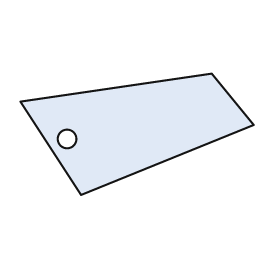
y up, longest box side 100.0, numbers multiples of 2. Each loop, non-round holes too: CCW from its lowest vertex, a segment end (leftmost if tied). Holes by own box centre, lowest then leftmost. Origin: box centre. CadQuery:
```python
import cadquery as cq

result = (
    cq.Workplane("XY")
    .moveTo(-24.0, -26.0)
    .lineTo(50.0, 4.0)
    .lineTo(32.0, 26.0)
    .lineTo(-50.0, 14.0)
    .close()
    .moveTo(-30.0, -2.0)
    .circle(4.0)
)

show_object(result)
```